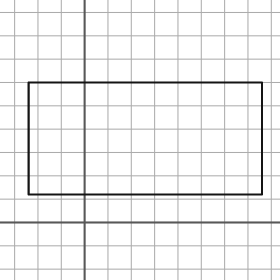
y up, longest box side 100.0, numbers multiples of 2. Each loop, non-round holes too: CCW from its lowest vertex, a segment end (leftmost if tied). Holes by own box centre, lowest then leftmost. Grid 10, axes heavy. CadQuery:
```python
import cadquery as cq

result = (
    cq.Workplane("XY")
    .moveTo(-24.0, 12.0)
    .lineTo(76.0, 12.0)
    .lineTo(76.0, 60.0)
    .lineTo(-24.0, 60.0)
    .close()
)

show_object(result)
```